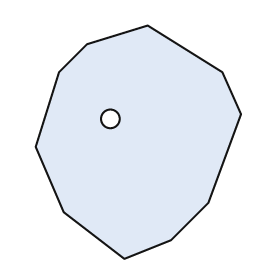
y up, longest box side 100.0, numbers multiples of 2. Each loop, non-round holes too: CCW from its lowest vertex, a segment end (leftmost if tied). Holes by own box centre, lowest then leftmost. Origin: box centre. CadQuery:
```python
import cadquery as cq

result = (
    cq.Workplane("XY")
    .moveTo(-6.0, -50.0)
    .lineTo(14.0, -42.0)
    .lineTo(30.0, -26.0)
    .lineTo(44.0, 12.0)
    .lineTo(36.0, 30.0)
    .lineTo(4.0, 50.0)
    .lineTo(-22.0, 42.0)
    .lineTo(-34.0, 30.0)
    .lineTo(-44.0, -2.0)
    .lineTo(-32.0, -30.0)
    .close()
    .moveTo(-12.0, 10.0)
    .circle(4.0)
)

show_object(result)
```